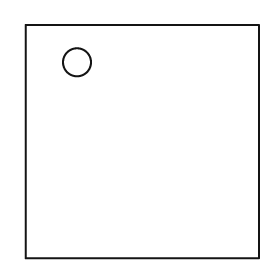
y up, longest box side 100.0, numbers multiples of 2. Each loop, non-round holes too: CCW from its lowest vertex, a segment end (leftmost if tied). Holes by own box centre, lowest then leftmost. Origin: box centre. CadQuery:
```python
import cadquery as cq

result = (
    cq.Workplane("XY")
    .moveTo(-50.0, -50.0)
    .lineTo(50.0, -50.0)
    .lineTo(50.0, 50.0)
    .lineTo(-50.0, 50.0)
    .close()
    .moveTo(-28.0, 34.0)
    .circle(6.0)
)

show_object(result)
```